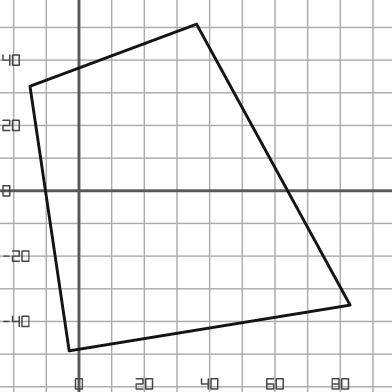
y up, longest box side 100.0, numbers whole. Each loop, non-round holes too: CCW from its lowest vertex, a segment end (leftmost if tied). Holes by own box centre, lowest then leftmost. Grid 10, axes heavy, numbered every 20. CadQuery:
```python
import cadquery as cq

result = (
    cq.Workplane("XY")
    .moveTo(-3.0, -49.0)
    .lineTo(83.0, -35.0)
    .lineTo(36.0, 51.0)
    .lineTo(-15.0, 32.0)
    .close()
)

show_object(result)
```